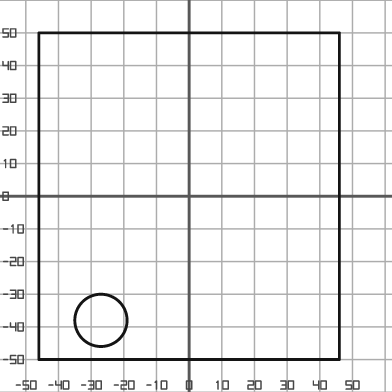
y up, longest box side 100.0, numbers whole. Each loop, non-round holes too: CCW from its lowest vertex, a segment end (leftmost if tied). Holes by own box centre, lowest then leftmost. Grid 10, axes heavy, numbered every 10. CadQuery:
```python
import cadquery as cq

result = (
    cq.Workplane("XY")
    .moveTo(-46.0, -50.0)
    .lineTo(46.0, -50.0)
    .lineTo(46.0, 50.0)
    .lineTo(-46.0, 50.0)
    .close()
    .moveTo(-27.0, -38.0)
    .circle(8.0)
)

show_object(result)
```